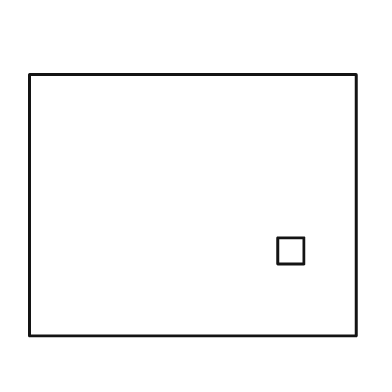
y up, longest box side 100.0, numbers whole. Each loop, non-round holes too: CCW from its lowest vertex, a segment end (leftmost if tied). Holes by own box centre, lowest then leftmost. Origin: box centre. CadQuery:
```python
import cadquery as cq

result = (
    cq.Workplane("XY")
    .moveTo(-50.0, -40.0)
    .lineTo(50.0, -40.0)
    .lineTo(50.0, 40.0)
    .lineTo(-50.0, 40.0)
    .close()
    .moveTo(26.0, -18.0)
    .lineTo(34.0, -18.0)
    .lineTo(34.0, -10.0)
    .lineTo(26.0, -10.0)
    .close()
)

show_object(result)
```